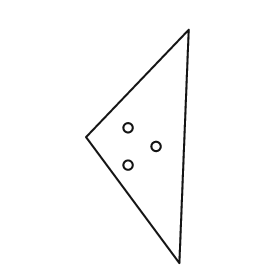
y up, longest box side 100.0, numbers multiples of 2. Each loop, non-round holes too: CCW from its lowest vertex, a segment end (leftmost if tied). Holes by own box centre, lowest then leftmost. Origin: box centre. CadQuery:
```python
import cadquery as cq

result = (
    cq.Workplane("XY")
    .moveTo(18.0, -50.0)
    .lineTo(22.0, 50.0)
    .lineTo(-22.0, 4.0)
    .close()
    .moveTo(-4.0, -8.0)
    .circle(2.0)
    .moveTo(8.0, 0.0)
    .circle(2.0)
    .moveTo(-4.0, 8.0)
    .circle(2.0)
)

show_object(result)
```